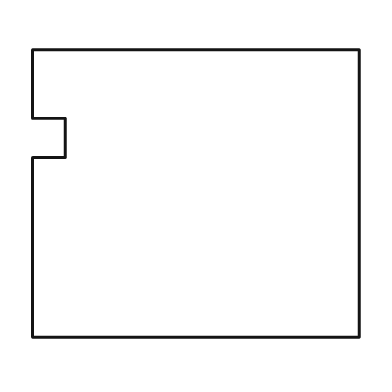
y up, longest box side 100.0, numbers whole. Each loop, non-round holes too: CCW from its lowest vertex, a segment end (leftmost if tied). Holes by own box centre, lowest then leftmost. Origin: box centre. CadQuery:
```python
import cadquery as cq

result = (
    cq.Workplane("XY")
    .moveTo(-50.0, -44.0)
    .lineTo(50.0, -44.0)
    .lineTo(50.0, 44.0)
    .lineTo(-50.0, 44.0)
    .lineTo(-50.0, 23.0)
    .lineTo(-40.0, 23.0)
    .lineTo(-40.0, 11.0)
    .lineTo(-50.0, 11.0)
    .close()
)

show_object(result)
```